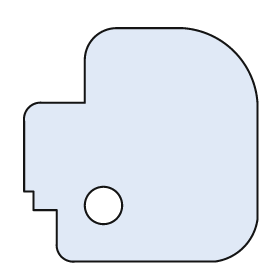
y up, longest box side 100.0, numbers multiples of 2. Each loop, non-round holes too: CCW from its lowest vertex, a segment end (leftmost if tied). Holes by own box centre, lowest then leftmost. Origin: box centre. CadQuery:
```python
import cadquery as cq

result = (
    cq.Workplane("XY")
    .moveTo(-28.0, -50.0)
    .lineTo(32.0, -50.0)
    .threePointArc((44.0, -44.0), (50.0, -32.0))
    .lineTo(50.0, 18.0)
    .threePointArc((40.0, 40.0), (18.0, 50.0))
    .lineTo(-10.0, 50.0)
    .threePointArc((-20.0, 46.0), (-24.0, 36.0))
    .lineTo(-24.0, 18.0)
    .lineTo(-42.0, 18.0)
    .threePointArc((-48.0, 16.0), (-50.0, 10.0))
    .lineTo(-50.0, -20.0)
    .lineTo(-46.0, -20.0)
    .lineTo(-46.0, -28.0)
    .lineTo(-36.0, -28.0)
    .lineTo(-36.0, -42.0)
    .threePointArc((-34.0, -48.0), (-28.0, -50.0))
    .close()
    .moveTo(-16.0, -26.0)
    .circle(8.0)
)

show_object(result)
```